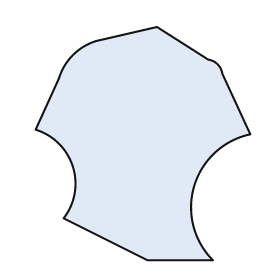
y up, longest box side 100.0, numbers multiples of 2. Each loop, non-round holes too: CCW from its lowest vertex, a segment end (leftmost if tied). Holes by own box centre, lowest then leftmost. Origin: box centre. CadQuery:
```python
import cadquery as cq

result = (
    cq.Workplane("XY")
    .moveTo(2.0, -50.0)
    .lineTo(30.0, -50.0)
    .threePointArc((22.0, -18.0), (46.0, 4.0))
    .lineTo(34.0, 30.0)
    .threePointArc((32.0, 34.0), (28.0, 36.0))
    .lineTo(6.0, 50.0)
    .lineTo(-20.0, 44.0)
    .threePointArc((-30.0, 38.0), (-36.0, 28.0))
    .lineTo(-46.0, 6.0)
    .threePointArc((-30.0, -10.0), (-34.0, -32.0))
    .close()
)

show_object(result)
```